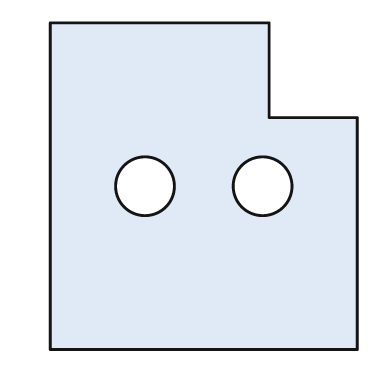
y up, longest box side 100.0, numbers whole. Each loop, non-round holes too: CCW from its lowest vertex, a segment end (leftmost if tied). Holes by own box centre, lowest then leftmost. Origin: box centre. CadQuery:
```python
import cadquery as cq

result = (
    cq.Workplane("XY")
    .moveTo(-47.0, -50.0)
    .lineTo(47.0, -50.0)
    .lineTo(47.0, 21.0)
    .lineTo(20.0, 21.0)
    .lineTo(20.0, 50.0)
    .lineTo(-47.0, 50.0)
    .close()
    .moveTo(-18.0, 0.0)
    .circle(9.0)
    .moveTo(18.0, 0.0)
    .circle(9.0)
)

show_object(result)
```